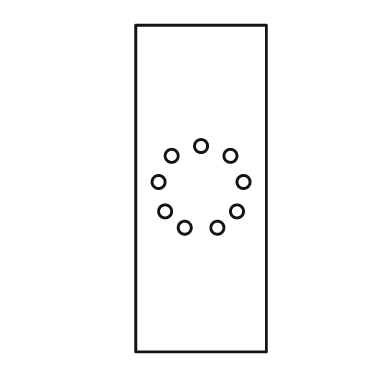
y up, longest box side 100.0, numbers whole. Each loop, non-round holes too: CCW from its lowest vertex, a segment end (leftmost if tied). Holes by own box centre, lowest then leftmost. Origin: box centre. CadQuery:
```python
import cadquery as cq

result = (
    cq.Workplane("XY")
    .moveTo(-20.0, -50.0)
    .lineTo(20.0, -50.0)
    .lineTo(20.0, 50.0)
    .lineTo(-20.0, 50.0)
    .close()
    .moveTo(-5.0, -12.0)
    .circle(2.0)
    .moveTo(5.0, -12.0)
    .circle(2.0)
    .moveTo(-11.0, -7.0)
    .circle(2.0)
    .moveTo(11.0, -7.0)
    .circle(2.0)
    .moveTo(-13.0, 2.0)
    .circle(2.0)
    .moveTo(13.0, 2.0)
    .circle(2.0)
    .moveTo(-9.0, 10.0)
    .circle(2.0)
    .moveTo(9.0, 10.0)
    .circle(2.0)
    .moveTo(0.0, 13.0)
    .circle(2.0)
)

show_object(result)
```